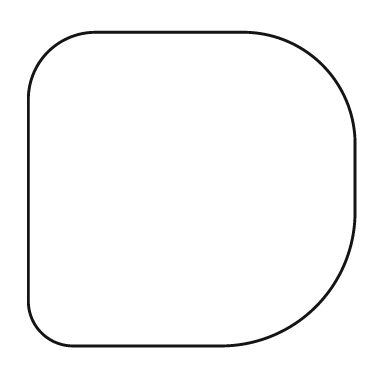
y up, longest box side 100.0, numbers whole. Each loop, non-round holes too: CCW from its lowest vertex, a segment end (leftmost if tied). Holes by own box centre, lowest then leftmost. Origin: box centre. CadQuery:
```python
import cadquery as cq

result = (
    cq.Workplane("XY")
    .moveTo(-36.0, -48.0)
    .lineTo(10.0, -48.0)
    .threePointArc((38.0, -36.0), (50.0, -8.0))
    .lineTo(50.0, 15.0)
    .threePointArc((40.0, 38.0), (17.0, 48.0))
    .lineTo(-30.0, 48.0)
    .threePointArc((-44.0, 42.0), (-50.0, 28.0))
    .lineTo(-50.0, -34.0)
    .threePointArc((-46.0, -44.0), (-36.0, -48.0))
    .close()
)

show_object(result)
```